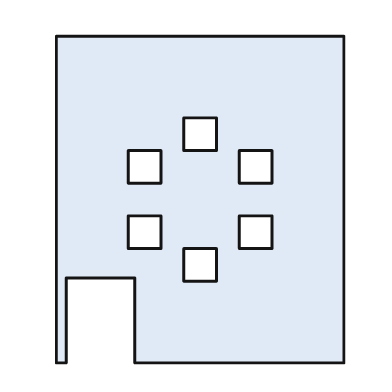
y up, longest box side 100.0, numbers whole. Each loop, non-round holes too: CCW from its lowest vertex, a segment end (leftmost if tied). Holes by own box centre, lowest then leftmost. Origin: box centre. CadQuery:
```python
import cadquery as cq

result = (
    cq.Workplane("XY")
    .moveTo(-44.0, -50.0)
    .lineTo(-41.0, -50.0)
    .lineTo(-41.0, -24.0)
    .lineTo(-20.0, -24.0)
    .lineTo(-20.0, -50.0)
    .lineTo(44.0, -50.0)
    .lineTo(44.0, 50.0)
    .lineTo(-44.0, 50.0)
    .close()
    .moveTo(-5.0, -25.0)
    .lineTo(5.0, -25.0)
    .lineTo(5.0, -15.0)
    .lineTo(-5.0, -15.0)
    .close()
    .moveTo(-22.0, -15.0)
    .lineTo(-12.0, -15.0)
    .lineTo(-12.0, -5.0)
    .lineTo(-22.0, -5.0)
    .close()
    .moveTo(12.0, -15.0)
    .lineTo(22.0, -15.0)
    .lineTo(22.0, -5.0)
    .lineTo(12.0, -5.0)
    .close()
    .moveTo(-22.0, 5.0)
    .lineTo(-12.0, 5.0)
    .lineTo(-12.0, 15.0)
    .lineTo(-22.0, 15.0)
    .close()
    .moveTo(12.0, 5.0)
    .lineTo(22.0, 5.0)
    .lineTo(22.0, 15.0)
    .lineTo(12.0, 15.0)
    .close()
    .moveTo(-5.0, 15.0)
    .lineTo(5.0, 15.0)
    .lineTo(5.0, 25.0)
    .lineTo(-5.0, 25.0)
    .close()
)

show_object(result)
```